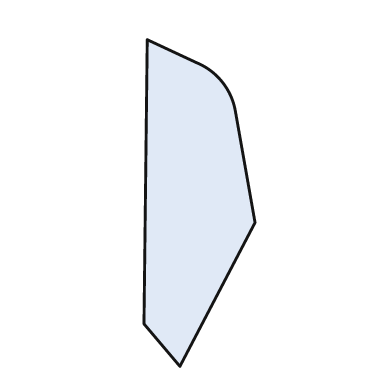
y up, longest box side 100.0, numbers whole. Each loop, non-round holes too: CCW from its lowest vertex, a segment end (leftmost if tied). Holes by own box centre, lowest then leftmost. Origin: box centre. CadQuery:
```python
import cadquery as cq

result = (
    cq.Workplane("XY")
    .moveTo(-6.0, -50.0)
    .lineTo(17.0, -6.0)
    .lineTo(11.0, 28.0)
    .threePointArc((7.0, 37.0), (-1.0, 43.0))
    .lineTo(-16.0, 50.0)
    .lineTo(-17.0, -37.0)
    .close()
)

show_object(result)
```